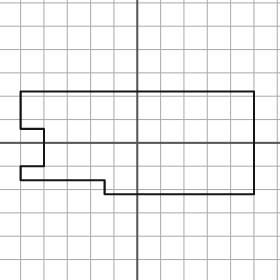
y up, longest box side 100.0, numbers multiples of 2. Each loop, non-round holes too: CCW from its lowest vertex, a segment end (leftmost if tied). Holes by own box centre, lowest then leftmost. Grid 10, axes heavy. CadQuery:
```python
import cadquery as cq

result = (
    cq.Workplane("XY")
    .moveTo(-14.0, -22.0)
    .lineTo(50.0, -22.0)
    .lineTo(50.0, 22.0)
    .lineTo(-50.0, 22.0)
    .lineTo(-50.0, 6.0)
    .lineTo(-40.0, 6.0)
    .lineTo(-40.0, -10.0)
    .lineTo(-50.0, -10.0)
    .lineTo(-50.0, -16.0)
    .lineTo(-14.0, -16.0)
    .close()
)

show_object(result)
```